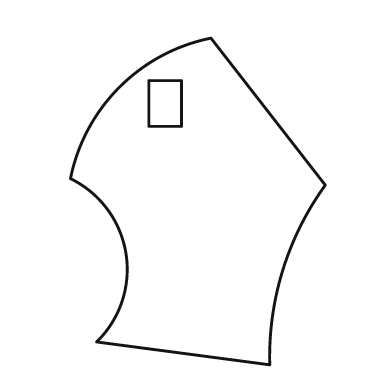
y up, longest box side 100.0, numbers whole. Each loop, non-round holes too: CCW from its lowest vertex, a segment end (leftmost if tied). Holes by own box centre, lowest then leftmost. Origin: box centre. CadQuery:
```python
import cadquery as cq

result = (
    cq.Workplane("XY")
    .moveTo(22.0, -50.0)
    .threePointArc((26.0, -21.0), (39.0, 5.0))
    .lineTo(4.0, 50.0)
    .threePointArc((-24.0, 35.0), (-39.0, 7.0))
    .threePointArc((-22.0, -16.0), (-31.0, -43.0))
    .close()
    .moveTo(-15.0, 23.0)
    .lineTo(-5.0, 23.0)
    .lineTo(-5.0, 37.0)
    .lineTo(-15.0, 37.0)
    .close()
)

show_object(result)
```